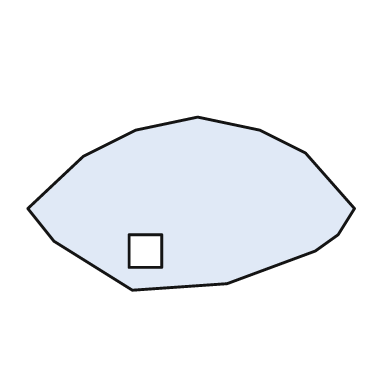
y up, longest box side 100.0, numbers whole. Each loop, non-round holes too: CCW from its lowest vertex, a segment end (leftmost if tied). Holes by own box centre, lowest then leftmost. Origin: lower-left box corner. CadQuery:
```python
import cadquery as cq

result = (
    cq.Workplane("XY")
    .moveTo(32.0, 0.0)
    .lineTo(61.0, 2.0)
    .lineTo(88.0, 12.0)
    .lineTo(95.0, 17.0)
    .lineTo(100.0, 25.0)
    .lineTo(85.0, 42.0)
    .lineTo(71.0, 49.0)
    .lineTo(52.0, 53.0)
    .lineTo(33.0, 49.0)
    .lineTo(17.0, 41.0)
    .lineTo(0.0, 25.0)
    .lineTo(8.0, 15.0)
    .close()
    .moveTo(31.0, 7.0)
    .lineTo(41.0, 7.0)
    .lineTo(41.0, 17.0)
    .lineTo(31.0, 17.0)
    .close()
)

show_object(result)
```